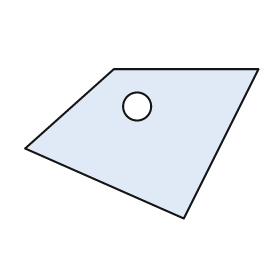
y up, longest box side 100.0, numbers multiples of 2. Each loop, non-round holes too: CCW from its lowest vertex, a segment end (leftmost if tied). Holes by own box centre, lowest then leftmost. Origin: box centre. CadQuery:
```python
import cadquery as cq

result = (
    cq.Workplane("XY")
    .moveTo(18.0, -32.0)
    .lineTo(50.0, 32.0)
    .lineTo(-12.0, 32.0)
    .lineTo(-50.0, -2.0)
    .close()
    .moveTo(-2.0, 16.0)
    .circle(6.0)
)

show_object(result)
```